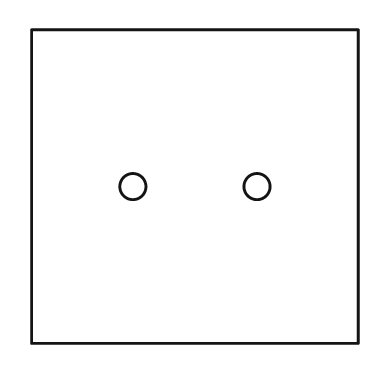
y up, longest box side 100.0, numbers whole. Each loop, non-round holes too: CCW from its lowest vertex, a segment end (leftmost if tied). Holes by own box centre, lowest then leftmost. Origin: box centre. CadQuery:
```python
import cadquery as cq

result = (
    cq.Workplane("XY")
    .moveTo(-50.0, -48.0)
    .lineTo(50.0, -48.0)
    .lineTo(50.0, 48.0)
    .lineTo(-50.0, 48.0)
    .close()
    .moveTo(-19.0, 0.0)
    .circle(4.0)
    .moveTo(19.0, 0.0)
    .circle(4.0)
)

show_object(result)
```